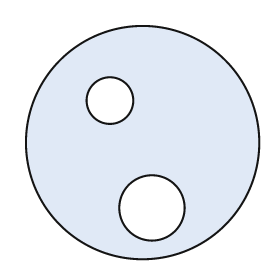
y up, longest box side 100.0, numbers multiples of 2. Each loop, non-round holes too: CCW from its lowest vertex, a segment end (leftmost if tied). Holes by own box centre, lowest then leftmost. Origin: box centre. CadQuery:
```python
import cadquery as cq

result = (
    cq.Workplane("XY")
    .moveTo(0.0, 0.0)
    .circle(50.0)
    .moveTo(4.0, -28.0)
    .circle(14.0)
    .moveTo(-14.0, 18.0)
    .circle(10.0)
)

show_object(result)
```